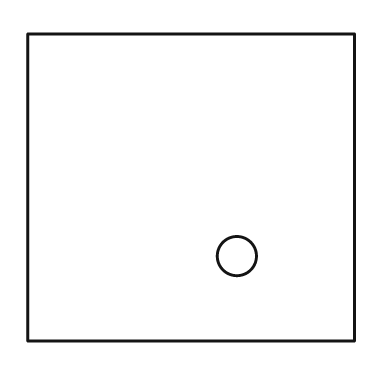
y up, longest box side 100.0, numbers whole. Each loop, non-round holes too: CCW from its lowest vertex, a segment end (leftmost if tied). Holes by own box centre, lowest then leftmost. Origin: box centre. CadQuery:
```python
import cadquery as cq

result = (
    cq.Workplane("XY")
    .moveTo(-50.0, -47.0)
    .lineTo(50.0, -47.0)
    .lineTo(50.0, 47.0)
    .lineTo(-50.0, 47.0)
    .close()
    .moveTo(14.0, -21.0)
    .circle(6.0)
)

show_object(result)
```